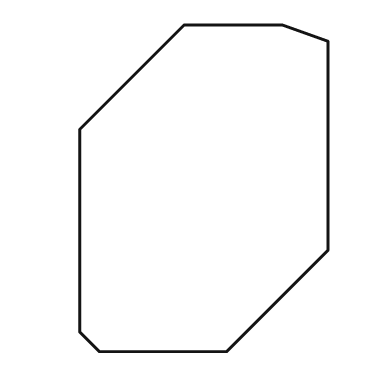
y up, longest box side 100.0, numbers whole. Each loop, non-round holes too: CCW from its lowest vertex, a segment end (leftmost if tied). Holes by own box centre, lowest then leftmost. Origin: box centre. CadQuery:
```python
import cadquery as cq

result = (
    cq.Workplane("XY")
    .moveTo(-32.0, -50.0)
    .lineTo(7.0, -50.0)
    .lineTo(38.0, -19.0)
    .lineTo(38.0, 45.0)
    .lineTo(24.0, 50.0)
    .lineTo(-6.0, 50.0)
    .lineTo(-38.0, 18.0)
    .lineTo(-38.0, -44.0)
    .close()
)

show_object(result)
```